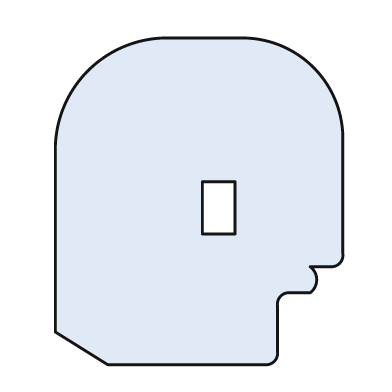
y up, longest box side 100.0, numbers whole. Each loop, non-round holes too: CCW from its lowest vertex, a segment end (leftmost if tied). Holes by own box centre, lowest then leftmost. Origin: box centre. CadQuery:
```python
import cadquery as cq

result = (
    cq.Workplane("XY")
    .moveTo(-28.0, -50.0)
    .lineTo(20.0, -50.0)
    .threePointArc((23.0, -49.0), (24.0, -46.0))
    .lineTo(24.0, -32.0)
    .threePointArc((25.0, -29.0), (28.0, -28.0))
    .lineTo(34.0, -28.0)
    .threePointArc((36.0, -24.0), (34.0, -20.0))
    .lineTo(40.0, -20.0)
    .threePointArc((43.0, -19.0), (44.0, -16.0))
    .lineTo(44.0, 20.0)
    .threePointArc((35.0, 41.0), (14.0, 50.0))
    .lineTo(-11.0, 50.0)
    .threePointArc((-34.0, 40.0), (-44.0, 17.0))
    .lineTo(-44.0, -40.0)
    .close()
    .moveTo(1.0, -10.0)
    .lineTo(11.0, -10.0)
    .lineTo(11.0, 6.0)
    .lineTo(1.0, 6.0)
    .close()
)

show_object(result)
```